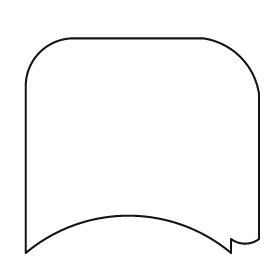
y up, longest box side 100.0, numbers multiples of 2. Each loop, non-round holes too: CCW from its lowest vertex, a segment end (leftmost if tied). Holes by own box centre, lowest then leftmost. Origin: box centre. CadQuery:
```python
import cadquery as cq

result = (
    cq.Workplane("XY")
    .moveTo(-50.0, -46.0)
    .threePointArc((-6.0, -30.0), (38.0, -46.0))
    .lineTo(38.0, -40.0)
    .threePointArc((44.0, -42.0), (50.0, -40.0))
    .lineTo(50.0, 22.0)
    .threePointArc((42.0, 38.0), (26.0, 46.0))
    .lineTo(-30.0, 46.0)
    .threePointArc((-44.0, 40.0), (-50.0, 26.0))
    .close()
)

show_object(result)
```